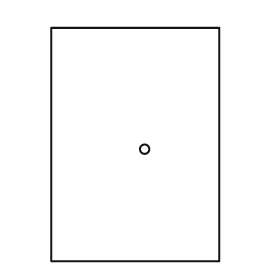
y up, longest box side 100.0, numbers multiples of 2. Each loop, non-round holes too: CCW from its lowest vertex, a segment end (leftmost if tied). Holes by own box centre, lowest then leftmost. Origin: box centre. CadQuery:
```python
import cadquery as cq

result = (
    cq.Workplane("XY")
    .moveTo(-36.0, -50.0)
    .lineTo(36.0, -50.0)
    .lineTo(36.0, 50.0)
    .lineTo(-36.0, 50.0)
    .close()
    .moveTo(4.0, -2.0)
    .circle(2.0)
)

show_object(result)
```